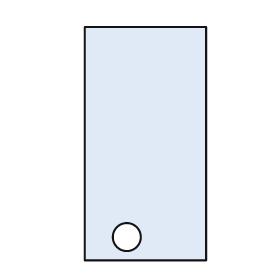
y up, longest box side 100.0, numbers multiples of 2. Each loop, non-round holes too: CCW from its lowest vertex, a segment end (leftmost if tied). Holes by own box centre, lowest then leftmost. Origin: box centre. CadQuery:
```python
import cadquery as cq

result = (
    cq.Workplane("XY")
    .moveTo(-26.0, -50.0)
    .lineTo(26.0, -50.0)
    .lineTo(26.0, 50.0)
    .lineTo(-26.0, 50.0)
    .close()
    .moveTo(-8.0, -40.0)
    .circle(6.0)
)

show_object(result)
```